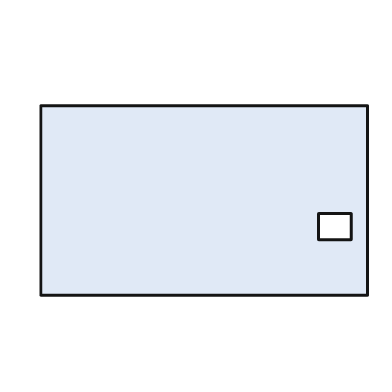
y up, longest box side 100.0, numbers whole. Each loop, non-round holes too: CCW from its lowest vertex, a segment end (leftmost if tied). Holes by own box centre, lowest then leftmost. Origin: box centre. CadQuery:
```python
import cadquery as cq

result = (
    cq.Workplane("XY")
    .moveTo(-50.0, -29.0)
    .lineTo(50.0, -29.0)
    .lineTo(50.0, 29.0)
    .lineTo(-50.0, 29.0)
    .close()
    .moveTo(35.0, -12.0)
    .lineTo(45.0, -12.0)
    .lineTo(45.0, -4.0)
    .lineTo(35.0, -4.0)
    .close()
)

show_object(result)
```